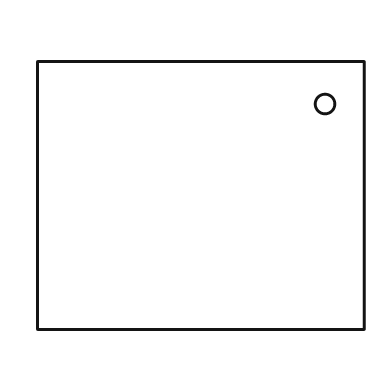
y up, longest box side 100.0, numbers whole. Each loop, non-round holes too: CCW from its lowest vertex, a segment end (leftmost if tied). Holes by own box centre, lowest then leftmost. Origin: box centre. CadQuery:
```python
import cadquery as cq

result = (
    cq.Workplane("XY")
    .moveTo(-50.0, -41.0)
    .lineTo(50.0, -41.0)
    .lineTo(50.0, 41.0)
    .lineTo(-50.0, 41.0)
    .close()
    .moveTo(38.0, 28.0)
    .circle(3.0)
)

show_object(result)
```